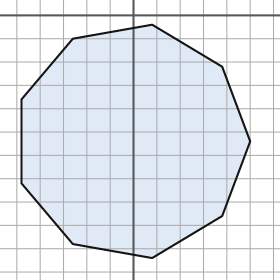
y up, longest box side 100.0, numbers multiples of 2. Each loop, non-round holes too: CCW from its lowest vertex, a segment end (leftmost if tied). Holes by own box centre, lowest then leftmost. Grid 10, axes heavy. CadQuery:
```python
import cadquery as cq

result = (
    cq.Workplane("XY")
    .moveTo(8.0, -104.0)
    .lineTo(38.0, -86.0)
    .lineTo(50.0, -54.0)
    .lineTo(38.0, -22.0)
    .lineTo(8.0, -4.0)
    .lineTo(-26.0, -10.0)
    .lineTo(-48.0, -36.0)
    .lineTo(-48.0, -72.0)
    .lineTo(-26.0, -98.0)
    .close()
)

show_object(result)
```